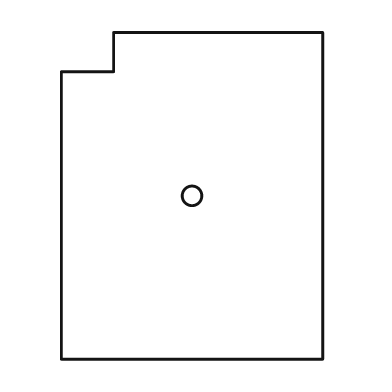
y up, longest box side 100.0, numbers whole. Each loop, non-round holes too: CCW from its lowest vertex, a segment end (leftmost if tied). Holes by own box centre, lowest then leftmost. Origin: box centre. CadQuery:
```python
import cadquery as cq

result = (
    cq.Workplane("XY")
    .moveTo(-40.0, -50.0)
    .lineTo(40.0, -50.0)
    .lineTo(40.0, 50.0)
    .lineTo(-24.0, 50.0)
    .lineTo(-24.0, 38.0)
    .lineTo(-40.0, 38.0)
    .close()
    .moveTo(0.0, 0.0)
    .circle(3.0)
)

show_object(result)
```